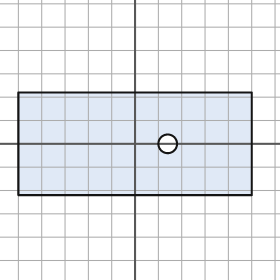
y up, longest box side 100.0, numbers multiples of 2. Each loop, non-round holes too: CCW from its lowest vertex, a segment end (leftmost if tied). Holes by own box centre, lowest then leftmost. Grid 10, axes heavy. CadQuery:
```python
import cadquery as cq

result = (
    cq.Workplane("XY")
    .moveTo(-50.0, -22.0)
    .lineTo(50.0, -22.0)
    .lineTo(50.0, 22.0)
    .lineTo(-50.0, 22.0)
    .close()
    .moveTo(14.0, 0.0)
    .circle(4.0)
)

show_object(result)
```